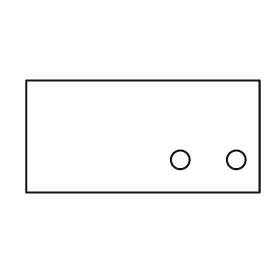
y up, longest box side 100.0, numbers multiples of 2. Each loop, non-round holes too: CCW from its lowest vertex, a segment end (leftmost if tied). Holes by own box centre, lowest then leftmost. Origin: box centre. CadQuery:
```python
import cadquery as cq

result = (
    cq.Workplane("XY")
    .moveTo(-50.0, -24.0)
    .lineTo(50.0, -24.0)
    .lineTo(50.0, 24.0)
    .lineTo(-50.0, 24.0)
    .close()
    .moveTo(16.0, -10.0)
    .circle(4.0)
    .moveTo(40.0, -10.0)
    .circle(4.0)
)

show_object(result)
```